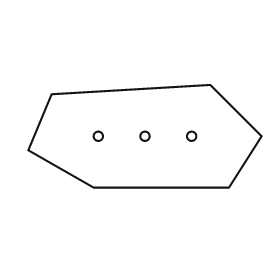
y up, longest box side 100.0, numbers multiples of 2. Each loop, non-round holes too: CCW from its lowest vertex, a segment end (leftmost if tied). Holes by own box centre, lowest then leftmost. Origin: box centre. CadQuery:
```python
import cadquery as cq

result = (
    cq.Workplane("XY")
    .moveTo(-22.0, -22.0)
    .lineTo(36.0, -22.0)
    .lineTo(50.0, 0.0)
    .lineTo(28.0, 22.0)
    .lineTo(-40.0, 18.0)
    .lineTo(-50.0, -6.0)
    .close()
    .moveTo(-20.0, 0.0)
    .circle(2.0)
    .moveTo(0.0, 0.0)
    .circle(2.0)
    .moveTo(20.0, 0.0)
    .circle(2.0)
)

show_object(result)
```